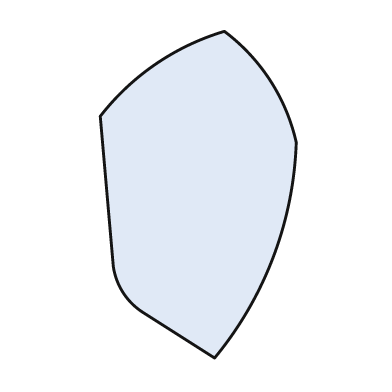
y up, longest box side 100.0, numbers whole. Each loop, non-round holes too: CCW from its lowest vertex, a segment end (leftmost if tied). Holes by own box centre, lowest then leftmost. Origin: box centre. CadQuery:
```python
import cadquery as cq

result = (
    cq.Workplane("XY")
    .moveTo(5.0, -50.0)
    .threePointArc((23.0, -19.0), (30.0, 16.0))
    .threePointArc((22.0, 35.0), (8.0, 50.0))
    .threePointArc((-13.0, 40.0), (-30.0, 24.0))
    .lineTo(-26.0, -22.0)
    .threePointArc((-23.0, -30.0), (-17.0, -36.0))
    .close()
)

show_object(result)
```